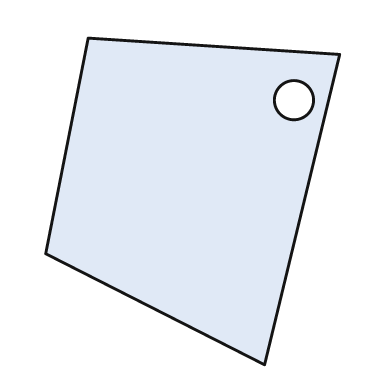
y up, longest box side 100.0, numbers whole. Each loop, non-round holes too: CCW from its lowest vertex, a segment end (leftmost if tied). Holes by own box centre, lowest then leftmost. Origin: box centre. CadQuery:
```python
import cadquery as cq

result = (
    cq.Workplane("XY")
    .moveTo(22.0, -50.0)
    .lineTo(45.0, 45.0)
    .lineTo(-32.0, 50.0)
    .lineTo(-45.0, -16.0)
    .close()
    .moveTo(31.0, 31.0)
    .circle(6.0)
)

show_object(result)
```